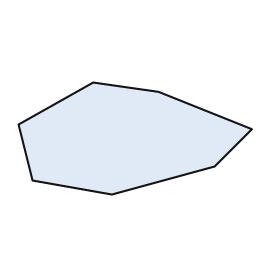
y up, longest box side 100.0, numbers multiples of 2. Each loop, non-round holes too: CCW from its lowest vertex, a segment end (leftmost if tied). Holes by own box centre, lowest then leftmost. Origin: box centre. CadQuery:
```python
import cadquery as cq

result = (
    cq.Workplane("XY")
    .moveTo(-10.0, -24.0)
    .lineTo(34.0, -12.0)
    .lineTo(50.0, 4.0)
    .lineTo(10.0, 20.0)
    .lineTo(-18.0, 24.0)
    .lineTo(-50.0, 6.0)
    .lineTo(-44.0, -18.0)
    .close()
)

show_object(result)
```